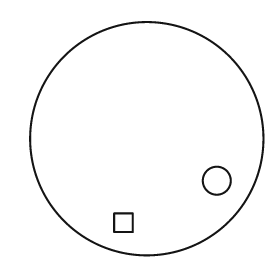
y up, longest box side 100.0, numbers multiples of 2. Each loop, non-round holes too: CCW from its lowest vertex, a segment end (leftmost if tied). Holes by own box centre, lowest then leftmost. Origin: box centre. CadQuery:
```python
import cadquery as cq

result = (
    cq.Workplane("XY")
    .moveTo(0.0, 0.0)
    .circle(50.0)
    .moveTo(-14.0, -40.0)
    .lineTo(-6.0, -40.0)
    .lineTo(-6.0, -32.0)
    .lineTo(-14.0, -32.0)
    .close()
    .moveTo(30.0, -18.0)
    .circle(6.0)
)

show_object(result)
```